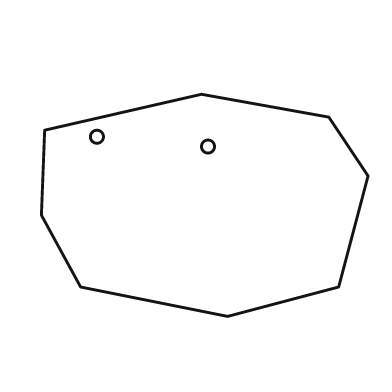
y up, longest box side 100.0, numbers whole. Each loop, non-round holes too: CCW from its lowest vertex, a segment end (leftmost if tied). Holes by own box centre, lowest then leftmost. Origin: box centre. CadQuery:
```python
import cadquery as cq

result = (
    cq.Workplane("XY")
    .moveTo(7.0, -34.0)
    .lineTo(41.0, -25.0)
    .lineTo(50.0, 9.0)
    .lineTo(38.0, 27.0)
    .lineTo(-1.0, 34.0)
    .lineTo(-49.0, 23.0)
    .lineTo(-50.0, -3.0)
    .lineTo(-38.0, -25.0)
    .close()
    .moveTo(1.0, 18.0)
    .circle(2.0)
    .moveTo(-33.0, 21.0)
    .circle(2.0)
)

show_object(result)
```